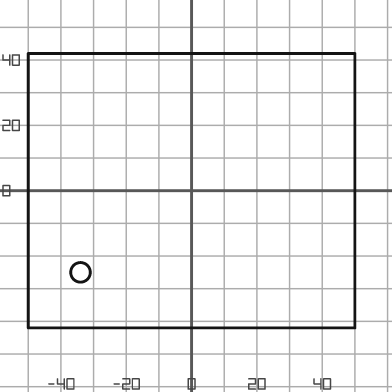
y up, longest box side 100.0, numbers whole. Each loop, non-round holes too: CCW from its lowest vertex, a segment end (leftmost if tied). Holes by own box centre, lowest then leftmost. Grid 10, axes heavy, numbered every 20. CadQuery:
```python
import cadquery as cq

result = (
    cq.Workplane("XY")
    .moveTo(-50.0, -42.0)
    .lineTo(50.0, -42.0)
    .lineTo(50.0, 42.0)
    .lineTo(-50.0, 42.0)
    .close()
    .moveTo(-34.0, -25.0)
    .circle(3.0)
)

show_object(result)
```